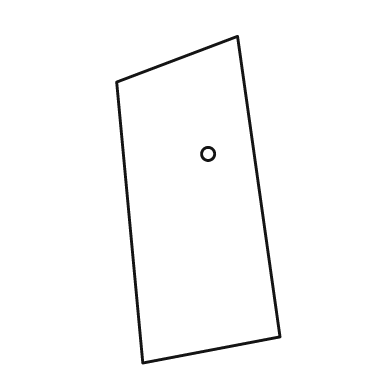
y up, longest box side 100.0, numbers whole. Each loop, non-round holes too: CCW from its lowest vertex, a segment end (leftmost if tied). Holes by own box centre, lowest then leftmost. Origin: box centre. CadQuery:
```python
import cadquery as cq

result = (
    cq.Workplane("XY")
    .moveTo(-17.0, -50.0)
    .lineTo(25.0, -42.0)
    .lineTo(12.0, 50.0)
    .lineTo(-25.0, 36.0)
    .close()
    .moveTo(3.0, 14.0)
    .circle(2.0)
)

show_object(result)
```